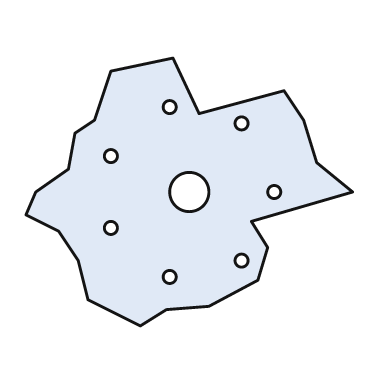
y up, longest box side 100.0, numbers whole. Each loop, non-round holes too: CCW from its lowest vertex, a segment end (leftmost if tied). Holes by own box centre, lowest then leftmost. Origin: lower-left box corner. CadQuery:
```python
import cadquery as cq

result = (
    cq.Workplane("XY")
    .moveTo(35.0, 0.0)
    .lineTo(43.0, 5.0)
    .lineTo(56.0, 6.0)
    .lineTo(71.0, 14.0)
    .lineTo(74.0, 24.0)
    .lineTo(69.0, 32.0)
    .lineTo(100.0, 41.0)
    .lineTo(89.0, 50.0)
    .lineTo(85.0, 63.0)
    .lineTo(79.0, 72.0)
    .lineTo(53.0, 65.0)
    .lineTo(45.0, 82.0)
    .lineTo(26.0, 78.0)
    .lineTo(21.0, 63.0)
    .lineTo(15.0, 59.0)
    .lineTo(13.0, 48.0)
    .lineTo(3.0, 41.0)
    .lineTo(0.0, 34.0)
    .lineTo(10.0, 29.0)
    .lineTo(16.0, 20.0)
    .lineTo(19.0, 8.0)
    .close()
    .moveTo(44.0, 15.0)
    .circle(2.0)
    .moveTo(66.0, 20.0)
    .circle(2.0)
    .moveTo(26.0, 30.0)
    .circle(2.0)
    .moveTo(50.0, 41.0)
    .circle(6.0)
    .moveTo(76.0, 41.0)
    .circle(2.0)
    .moveTo(26.0, 52.0)
    .circle(2.0)
    .moveTo(66.0, 62.0)
    .circle(2.0)
    .moveTo(44.0, 67.0)
    .circle(2.0)
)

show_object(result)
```